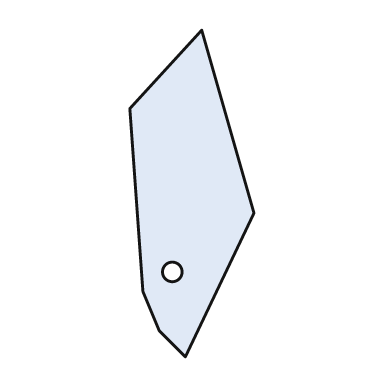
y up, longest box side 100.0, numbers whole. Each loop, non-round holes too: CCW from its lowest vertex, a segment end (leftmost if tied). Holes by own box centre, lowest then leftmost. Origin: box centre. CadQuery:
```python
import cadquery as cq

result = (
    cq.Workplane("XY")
    .moveTo(-2.0, -50.0)
    .lineTo(19.0, -6.0)
    .lineTo(3.0, 50.0)
    .lineTo(-19.0, 26.0)
    .lineTo(-15.0, -30.0)
    .lineTo(-10.0, -42.0)
    .close()
    .moveTo(-6.0, -24.0)
    .circle(3.0)
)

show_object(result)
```